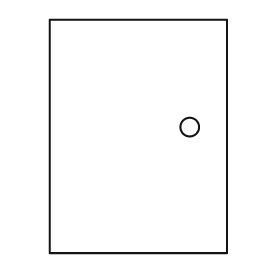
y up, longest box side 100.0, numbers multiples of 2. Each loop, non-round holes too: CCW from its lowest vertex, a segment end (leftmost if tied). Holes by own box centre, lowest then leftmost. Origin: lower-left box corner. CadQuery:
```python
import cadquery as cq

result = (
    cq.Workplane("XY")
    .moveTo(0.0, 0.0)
    .lineTo(76.0, 0.0)
    .lineTo(76.0, 100.0)
    .lineTo(0.0, 100.0)
    .close()
    .moveTo(60.0, 54.0)
    .circle(4.0)
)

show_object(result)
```